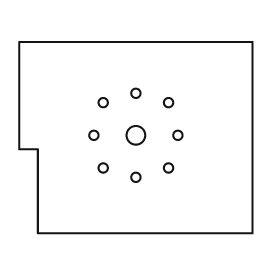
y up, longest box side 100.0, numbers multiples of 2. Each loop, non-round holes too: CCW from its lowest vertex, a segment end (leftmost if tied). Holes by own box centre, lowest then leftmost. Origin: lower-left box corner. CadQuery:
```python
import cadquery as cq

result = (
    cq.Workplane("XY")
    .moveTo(8.0, 0.0)
    .lineTo(100.0, 0.0)
    .lineTo(100.0, 82.0)
    .lineTo(0.0, 82.0)
    .lineTo(0.0, 36.0)
    .lineTo(8.0, 36.0)
    .close()
    .moveTo(50.0, 24.0)
    .circle(2.0)
    .moveTo(36.0, 28.0)
    .circle(2.0)
    .moveTo(64.0, 28.0)
    .circle(2.0)
    .moveTo(32.0, 42.0)
    .circle(2.0)
    .moveTo(50.0, 42.0)
    .circle(4.0)
    .moveTo(68.0, 42.0)
    .circle(2.0)
    .moveTo(36.0, 56.0)
    .circle(2.0)
    .moveTo(64.0, 56.0)
    .circle(2.0)
    .moveTo(50.0, 60.0)
    .circle(2.0)
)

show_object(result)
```